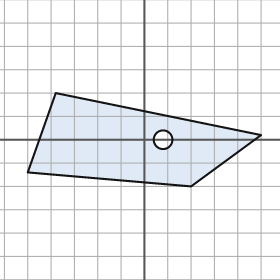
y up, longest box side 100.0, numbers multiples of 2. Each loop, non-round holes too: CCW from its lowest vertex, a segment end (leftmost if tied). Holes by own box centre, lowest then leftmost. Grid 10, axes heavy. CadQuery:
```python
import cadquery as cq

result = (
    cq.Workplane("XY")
    .moveTo(20.0, -20.0)
    .lineTo(50.0, 2.0)
    .lineTo(-38.0, 20.0)
    .lineTo(-50.0, -14.0)
    .close()
    .moveTo(8.0, 0.0)
    .circle(4.0)
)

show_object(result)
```